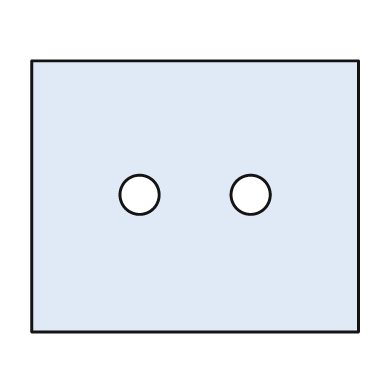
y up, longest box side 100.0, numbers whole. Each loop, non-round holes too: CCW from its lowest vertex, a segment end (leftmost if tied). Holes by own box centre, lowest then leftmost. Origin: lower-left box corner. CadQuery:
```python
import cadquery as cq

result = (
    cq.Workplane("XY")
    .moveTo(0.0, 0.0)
    .lineTo(100.0, 0.0)
    .lineTo(100.0, 83.0)
    .lineTo(0.0, 83.0)
    .close()
    .moveTo(33.0, 42.0)
    .circle(6.0)
    .moveTo(67.0, 42.0)
    .circle(6.0)
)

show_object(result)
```